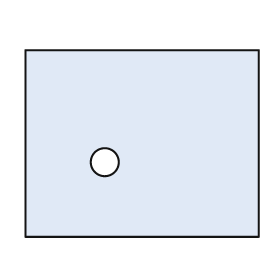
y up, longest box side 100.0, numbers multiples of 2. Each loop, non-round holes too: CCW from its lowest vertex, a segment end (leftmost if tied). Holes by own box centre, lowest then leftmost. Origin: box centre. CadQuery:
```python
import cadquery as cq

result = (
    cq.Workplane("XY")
    .moveTo(-50.0, -40.0)
    .lineTo(50.0, -40.0)
    .lineTo(50.0, 40.0)
    .lineTo(-50.0, 40.0)
    .close()
    .moveTo(-16.0, -8.0)
    .circle(6.0)
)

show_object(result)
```